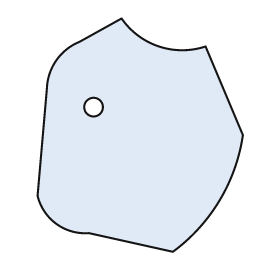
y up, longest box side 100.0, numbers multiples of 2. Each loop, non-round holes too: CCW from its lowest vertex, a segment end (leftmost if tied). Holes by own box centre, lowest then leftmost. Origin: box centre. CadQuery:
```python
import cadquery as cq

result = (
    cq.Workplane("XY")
    .moveTo(14.0, -50.0)
    .threePointArc((34.0, -28.0), (44.0, 0.0))
    .lineTo(28.0, 38.0)
    .threePointArc((8.0, 38.0), (-8.0, 50.0))
    .lineTo(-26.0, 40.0)
    .threePointArc((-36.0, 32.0), (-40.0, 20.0))
    .lineTo(-44.0, -26.0)
    .threePointArc((-36.0, -38.0), (-22.0, -42.0))
    .close()
    .moveTo(-20.0, 12.0)
    .circle(4.0)
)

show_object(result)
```